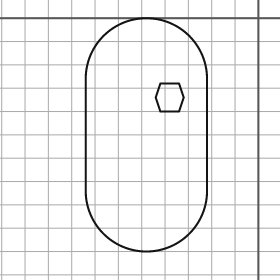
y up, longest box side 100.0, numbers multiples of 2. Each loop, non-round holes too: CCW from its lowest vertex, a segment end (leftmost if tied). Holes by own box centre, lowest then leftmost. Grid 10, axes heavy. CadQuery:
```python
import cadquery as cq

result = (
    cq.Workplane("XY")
    .moveTo(-74.0, -74.0)
    .threePointArc((-48.0, -100.0), (-22.0, -74.0))
    .lineTo(-22.0, -26.0)
    .threePointArc((-48.0, 0.0), (-74.0, -26.0))
    .close()
    .moveTo(-42.0, -40.0)
    .lineTo(-34.0, -40.0)
    .lineTo(-32.0, -34.0)
    .lineTo(-34.0, -28.0)
    .lineTo(-42.0, -28.0)
    .lineTo(-44.0, -34.0)
    .close()
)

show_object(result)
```